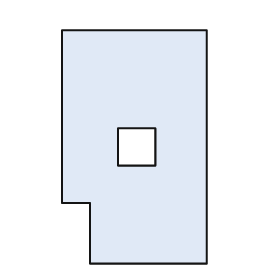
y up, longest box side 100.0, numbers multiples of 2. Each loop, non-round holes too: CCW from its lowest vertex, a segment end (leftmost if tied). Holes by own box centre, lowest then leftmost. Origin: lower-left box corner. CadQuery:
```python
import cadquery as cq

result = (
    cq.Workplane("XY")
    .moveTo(12.0, 0.0)
    .lineTo(62.0, 0.0)
    .lineTo(62.0, 100.0)
    .lineTo(0.0, 100.0)
    .lineTo(0.0, 26.0)
    .lineTo(12.0, 26.0)
    .close()
    .moveTo(24.0, 42.0)
    .lineTo(40.0, 42.0)
    .lineTo(40.0, 58.0)
    .lineTo(24.0, 58.0)
    .close()
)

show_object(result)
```